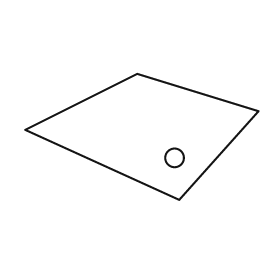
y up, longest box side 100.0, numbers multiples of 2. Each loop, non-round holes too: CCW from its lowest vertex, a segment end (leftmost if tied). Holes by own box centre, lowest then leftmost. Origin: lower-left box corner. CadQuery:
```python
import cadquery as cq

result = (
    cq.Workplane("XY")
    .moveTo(66.0, 0.0)
    .lineTo(100.0, 38.0)
    .lineTo(48.0, 54.0)
    .lineTo(0.0, 30.0)
    .close()
    .moveTo(64.0, 18.0)
    .circle(4.0)
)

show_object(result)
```